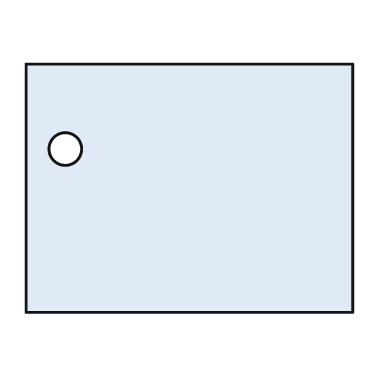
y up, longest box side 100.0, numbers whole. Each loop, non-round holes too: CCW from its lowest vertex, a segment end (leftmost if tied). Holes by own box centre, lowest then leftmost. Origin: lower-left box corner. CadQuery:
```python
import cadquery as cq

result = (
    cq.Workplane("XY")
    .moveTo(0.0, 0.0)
    .lineTo(100.0, 0.0)
    .lineTo(100.0, 76.0)
    .lineTo(0.0, 76.0)
    .close()
    .moveTo(12.0, 50.0)
    .circle(5.0)
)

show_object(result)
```